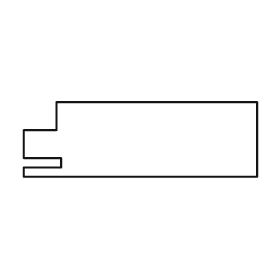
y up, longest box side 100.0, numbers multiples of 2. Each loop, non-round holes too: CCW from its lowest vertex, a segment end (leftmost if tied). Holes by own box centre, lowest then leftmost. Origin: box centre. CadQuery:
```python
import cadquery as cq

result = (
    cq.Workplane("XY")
    .moveTo(-50.0, -16.0)
    .lineTo(50.0, -16.0)
    .lineTo(50.0, 16.0)
    .lineTo(-36.0, 16.0)
    .lineTo(-36.0, 4.0)
    .lineTo(-50.0, 4.0)
    .lineTo(-50.0, -8.0)
    .lineTo(-34.0, -8.0)
    .lineTo(-34.0, -12.0)
    .lineTo(-50.0, -12.0)
    .close()
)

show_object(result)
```